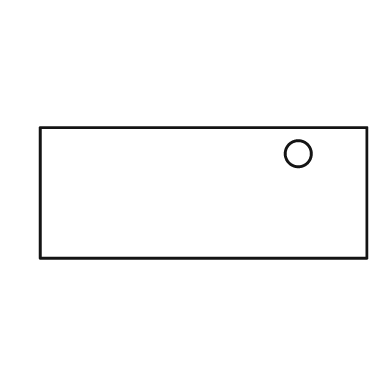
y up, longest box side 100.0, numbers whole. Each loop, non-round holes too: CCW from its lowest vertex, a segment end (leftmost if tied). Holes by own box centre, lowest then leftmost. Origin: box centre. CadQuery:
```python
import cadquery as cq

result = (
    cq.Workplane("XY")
    .moveTo(-50.0, -20.0)
    .lineTo(50.0, -20.0)
    .lineTo(50.0, 20.0)
    .lineTo(-50.0, 20.0)
    .close()
    .moveTo(29.0, 12.0)
    .circle(4.0)
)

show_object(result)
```